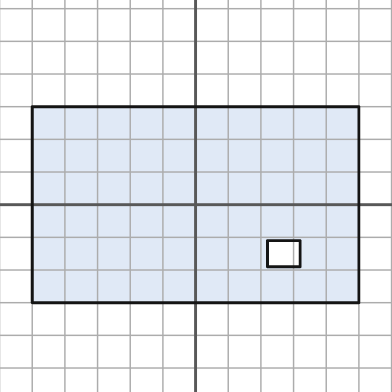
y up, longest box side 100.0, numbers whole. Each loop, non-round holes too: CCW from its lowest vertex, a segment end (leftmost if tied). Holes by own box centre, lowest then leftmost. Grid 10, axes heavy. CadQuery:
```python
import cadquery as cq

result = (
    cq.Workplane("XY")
    .moveTo(-50.0, -30.0)
    .lineTo(50.0, -30.0)
    .lineTo(50.0, 30.0)
    .lineTo(-50.0, 30.0)
    .close()
    .moveTo(22.0, -19.0)
    .lineTo(32.0, -19.0)
    .lineTo(32.0, -11.0)
    .lineTo(22.0, -11.0)
    .close()
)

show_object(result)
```